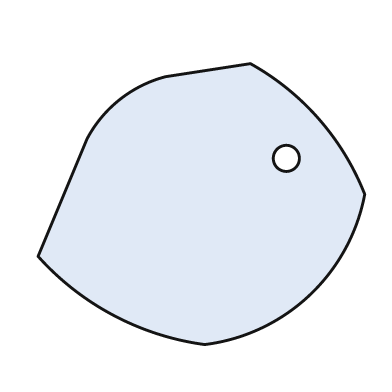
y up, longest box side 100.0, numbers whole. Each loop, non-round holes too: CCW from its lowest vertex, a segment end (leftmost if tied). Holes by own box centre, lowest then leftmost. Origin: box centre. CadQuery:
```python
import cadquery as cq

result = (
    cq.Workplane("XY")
    .moveTo(1.0, -43.0)
    .threePointArc((33.0, -28.0), (50.0, 3.0))
    .threePointArc((36.0, 26.0), (15.0, 43.0))
    .lineTo(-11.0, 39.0)
    .threePointArc((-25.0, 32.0), (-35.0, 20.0))
    .lineTo(-50.0, -16.0)
    .threePointArc((-27.0, -34.0), (1.0, -43.0))
    .close()
    .moveTo(26.0, 14.0)
    .circle(4.0)
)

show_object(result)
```